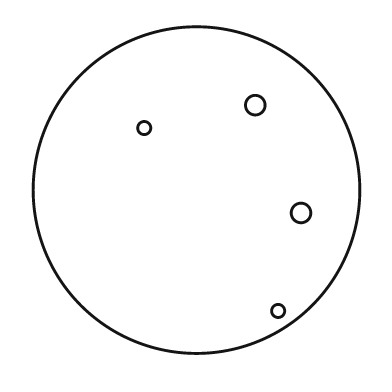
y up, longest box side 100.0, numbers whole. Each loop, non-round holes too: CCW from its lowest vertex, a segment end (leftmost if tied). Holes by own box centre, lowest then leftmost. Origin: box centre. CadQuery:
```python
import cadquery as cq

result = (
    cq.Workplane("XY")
    .moveTo(0.0, 0.0)
    .circle(50.0)
    .moveTo(25.0, -37.0)
    .circle(2.0)
    .moveTo(32.0, -7.0)
    .circle(3.0)
    .moveTo(-16.0, 19.0)
    .circle(2.0)
    .moveTo(18.0, 26.0)
    .circle(3.0)
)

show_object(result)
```